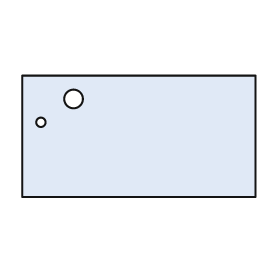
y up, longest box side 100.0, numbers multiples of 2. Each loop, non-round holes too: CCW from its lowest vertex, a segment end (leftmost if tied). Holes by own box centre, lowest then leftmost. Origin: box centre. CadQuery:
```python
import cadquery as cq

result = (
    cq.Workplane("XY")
    .moveTo(-50.0, -26.0)
    .lineTo(50.0, -26.0)
    .lineTo(50.0, 26.0)
    .lineTo(-50.0, 26.0)
    .close()
    .moveTo(-42.0, 6.0)
    .circle(2.0)
    .moveTo(-28.0, 16.0)
    .circle(4.0)
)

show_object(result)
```